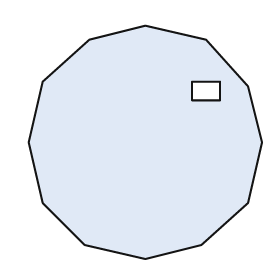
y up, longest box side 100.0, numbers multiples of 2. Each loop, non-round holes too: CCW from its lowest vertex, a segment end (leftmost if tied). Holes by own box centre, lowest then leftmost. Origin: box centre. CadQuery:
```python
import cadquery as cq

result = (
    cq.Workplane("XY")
    .moveTo(0.0, -50.0)
    .lineTo(24.0, -44.0)
    .lineTo(44.0, -26.0)
    .lineTo(50.0, 0.0)
    .lineTo(44.0, 24.0)
    .lineTo(26.0, 44.0)
    .lineTo(0.0, 50.0)
    .lineTo(-24.0, 44.0)
    .lineTo(-44.0, 26.0)
    .lineTo(-50.0, 0.0)
    .lineTo(-44.0, -26.0)
    .lineTo(-26.0, -44.0)
    .close()
    .moveTo(20.0, 18.0)
    .lineTo(32.0, 18.0)
    .lineTo(32.0, 26.0)
    .lineTo(20.0, 26.0)
    .close()
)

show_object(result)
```